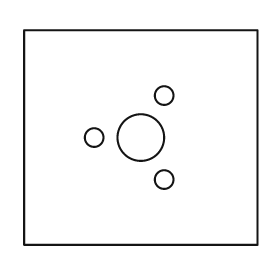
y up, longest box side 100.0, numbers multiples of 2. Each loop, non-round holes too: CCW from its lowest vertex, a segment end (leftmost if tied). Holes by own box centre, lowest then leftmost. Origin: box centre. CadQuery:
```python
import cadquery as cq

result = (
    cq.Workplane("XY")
    .moveTo(-50.0, -46.0)
    .lineTo(50.0, -46.0)
    .lineTo(50.0, 46.0)
    .lineTo(-50.0, 46.0)
    .close()
    .moveTo(10.0, -18.0)
    .circle(4.0)
    .moveTo(-20.0, 0.0)
    .circle(4.0)
    .moveTo(0.0, 0.0)
    .circle(10.0)
    .moveTo(10.0, 18.0)
    .circle(4.0)
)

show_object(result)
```